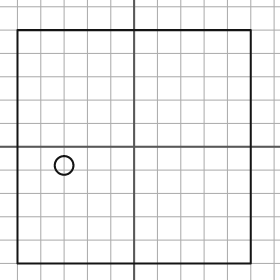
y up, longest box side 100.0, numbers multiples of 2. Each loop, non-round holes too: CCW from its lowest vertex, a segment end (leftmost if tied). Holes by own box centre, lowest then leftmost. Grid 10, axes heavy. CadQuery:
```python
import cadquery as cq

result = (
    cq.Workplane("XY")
    .moveTo(-50.0, -50.0)
    .lineTo(50.0, -50.0)
    .lineTo(50.0, 50.0)
    .lineTo(-50.0, 50.0)
    .close()
    .moveTo(-30.0, -8.0)
    .circle(4.0)
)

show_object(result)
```